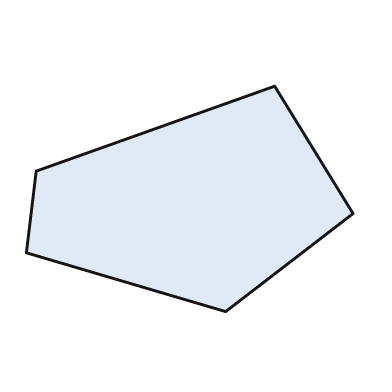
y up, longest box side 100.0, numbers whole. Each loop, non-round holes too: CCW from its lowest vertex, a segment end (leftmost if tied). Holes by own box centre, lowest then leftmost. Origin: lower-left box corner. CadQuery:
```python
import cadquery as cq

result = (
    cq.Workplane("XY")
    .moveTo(61.0, 0.0)
    .lineTo(100.0, 30.0)
    .lineTo(76.0, 69.0)
    .lineTo(3.0, 43.0)
    .lineTo(0.0, 18.0)
    .close()
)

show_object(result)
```